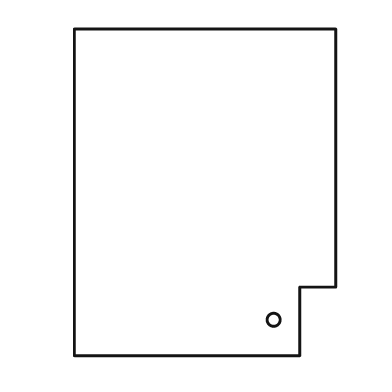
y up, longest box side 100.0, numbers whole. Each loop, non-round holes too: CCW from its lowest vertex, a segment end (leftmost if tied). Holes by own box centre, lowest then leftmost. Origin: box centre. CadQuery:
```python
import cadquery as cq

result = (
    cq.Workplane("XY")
    .moveTo(-40.0, -50.0)
    .lineTo(29.0, -50.0)
    .lineTo(29.0, -29.0)
    .lineTo(40.0, -29.0)
    .lineTo(40.0, 50.0)
    .lineTo(-40.0, 50.0)
    .close()
    .moveTo(21.0, -39.0)
    .circle(2.0)
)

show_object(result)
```